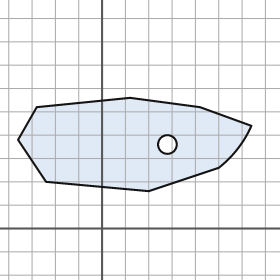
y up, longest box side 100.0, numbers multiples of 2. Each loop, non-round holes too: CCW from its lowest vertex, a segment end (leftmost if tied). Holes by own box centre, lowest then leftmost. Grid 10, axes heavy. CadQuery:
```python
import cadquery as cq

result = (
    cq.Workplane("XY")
    .moveTo(20.0, 16.0)
    .lineTo(50.0, 26.0)
    .threePointArc((58.0, 34.0), (64.0, 44.0))
    .lineTo(42.0, 52.0)
    .lineTo(12.0, 56.0)
    .lineTo(-28.0, 52.0)
    .lineTo(-36.0, 38.0)
    .lineTo(-24.0, 20.0)
    .close()
    .moveTo(28.0, 36.0)
    .circle(4.0)
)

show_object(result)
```